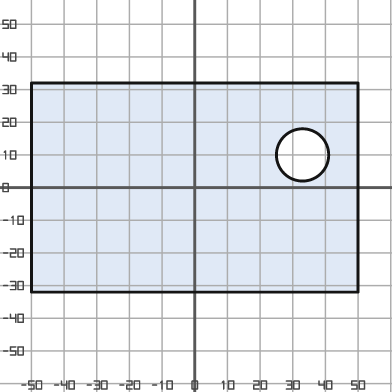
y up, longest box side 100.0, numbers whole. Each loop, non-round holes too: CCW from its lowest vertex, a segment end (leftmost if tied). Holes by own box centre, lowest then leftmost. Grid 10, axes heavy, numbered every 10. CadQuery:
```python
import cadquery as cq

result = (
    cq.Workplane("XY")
    .moveTo(-50.0, -32.0)
    .lineTo(50.0, -32.0)
    .lineTo(50.0, 32.0)
    .lineTo(-50.0, 32.0)
    .close()
    .moveTo(33.0, 10.0)
    .circle(8.0)
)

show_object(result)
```